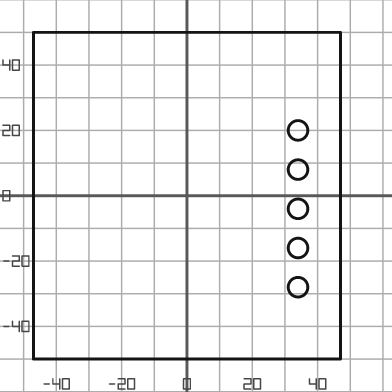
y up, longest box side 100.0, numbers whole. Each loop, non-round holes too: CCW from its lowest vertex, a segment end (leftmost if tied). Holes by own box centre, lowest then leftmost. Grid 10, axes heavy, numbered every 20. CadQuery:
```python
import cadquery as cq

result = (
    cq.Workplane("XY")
    .moveTo(-47.0, -50.0)
    .lineTo(47.0, -50.0)
    .lineTo(47.0, 50.0)
    .lineTo(-47.0, 50.0)
    .close()
    .moveTo(34.0, -28.0)
    .circle(3.0)
    .moveTo(34.0, -16.0)
    .circle(3.0)
    .moveTo(34.0, -4.0)
    .circle(3.0)
    .moveTo(34.0, 8.0)
    .circle(3.0)
    .moveTo(34.0, 20.0)
    .circle(3.0)
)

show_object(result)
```